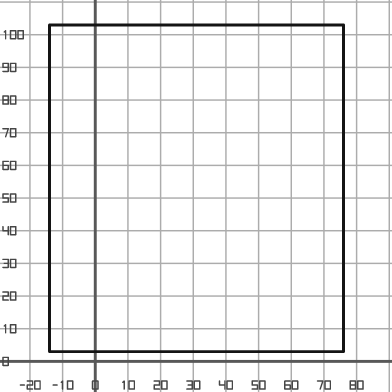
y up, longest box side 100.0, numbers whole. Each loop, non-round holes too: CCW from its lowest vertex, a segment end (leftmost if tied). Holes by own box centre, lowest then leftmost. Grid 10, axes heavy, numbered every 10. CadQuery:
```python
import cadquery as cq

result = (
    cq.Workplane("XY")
    .moveTo(-14.0, 3.0)
    .lineTo(76.0, 3.0)
    .lineTo(76.0, 103.0)
    .lineTo(-14.0, 103.0)
    .close()
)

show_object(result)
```